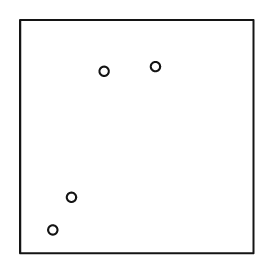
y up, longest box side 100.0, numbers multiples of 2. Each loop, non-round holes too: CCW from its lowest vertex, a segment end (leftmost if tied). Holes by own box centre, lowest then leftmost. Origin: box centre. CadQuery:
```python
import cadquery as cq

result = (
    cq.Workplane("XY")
    .moveTo(-50.0, -50.0)
    .lineTo(50.0, -50.0)
    .lineTo(50.0, 50.0)
    .lineTo(-50.0, 50.0)
    .close()
    .moveTo(-36.0, -40.0)
    .circle(2.0)
    .moveTo(-28.0, -26.0)
    .circle(2.0)
    .moveTo(-14.0, 28.0)
    .circle(2.0)
    .moveTo(8.0, 30.0)
    .circle(2.0)
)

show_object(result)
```